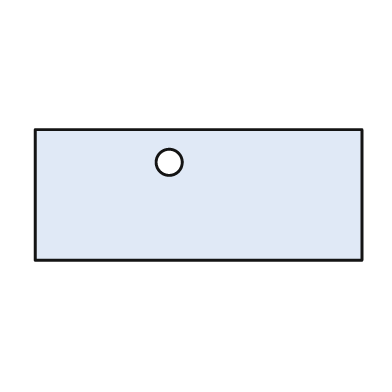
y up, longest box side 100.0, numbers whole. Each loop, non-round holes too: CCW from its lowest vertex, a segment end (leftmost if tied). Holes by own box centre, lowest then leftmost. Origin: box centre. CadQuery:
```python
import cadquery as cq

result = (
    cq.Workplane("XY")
    .moveTo(-50.0, -20.0)
    .lineTo(50.0, -20.0)
    .lineTo(50.0, 20.0)
    .lineTo(-50.0, 20.0)
    .close()
    .moveTo(-9.0, 10.0)
    .circle(4.0)
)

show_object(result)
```